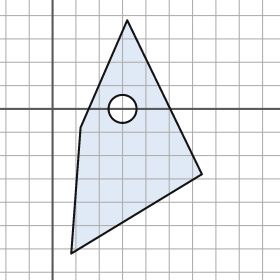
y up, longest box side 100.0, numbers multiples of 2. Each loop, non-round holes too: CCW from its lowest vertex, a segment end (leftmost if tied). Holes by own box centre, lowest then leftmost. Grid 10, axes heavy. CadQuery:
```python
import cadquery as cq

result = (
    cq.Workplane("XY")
    .moveTo(8.0, -62.0)
    .lineTo(64.0, -28.0)
    .lineTo(32.0, 38.0)
    .lineTo(12.0, -8.0)
    .close()
    .moveTo(30.0, 0.0)
    .circle(6.0)
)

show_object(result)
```